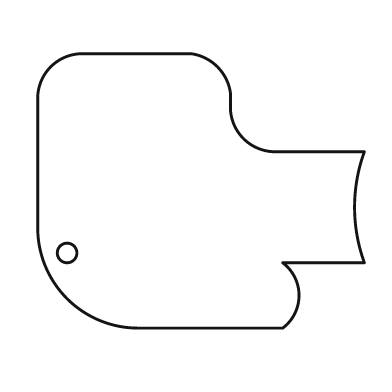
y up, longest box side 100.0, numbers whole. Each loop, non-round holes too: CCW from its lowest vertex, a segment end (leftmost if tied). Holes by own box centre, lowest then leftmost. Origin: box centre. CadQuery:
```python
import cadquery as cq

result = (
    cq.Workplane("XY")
    .moveTo(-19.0, -42.0)
    .lineTo(25.0, -42.0)
    .threePointArc((30.0, -32.0), (25.0, -22.0))
    .lineTo(50.0, -22.0)
    .threePointArc((47.0, -5.0), (50.0, 12.0))
    .lineTo(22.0, 12.0)
    .threePointArc((13.0, 16.0), (9.0, 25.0))
    .lineTo(9.0, 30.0)
    .threePointArc((5.0, 38.0), (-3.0, 42.0))
    .lineTo(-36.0, 42.0)
    .threePointArc((-46.0, 38.0), (-50.0, 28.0))
    .lineTo(-50.0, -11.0)
    .threePointArc((-41.0, -33.0), (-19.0, -42.0))
    .close()
    .moveTo(-41.0, -19.0)
    .circle(3.0)
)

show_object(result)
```